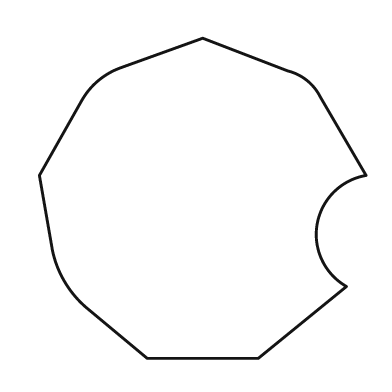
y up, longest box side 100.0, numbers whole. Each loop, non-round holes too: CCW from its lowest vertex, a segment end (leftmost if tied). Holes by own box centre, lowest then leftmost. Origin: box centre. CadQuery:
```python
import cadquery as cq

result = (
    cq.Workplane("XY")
    .moveTo(-17.0, -49.0)
    .lineTo(17.0, -49.0)
    .lineTo(44.0, -27.0)
    .threePointArc((35.0, -8.0), (50.0, 7.0))
    .lineTo(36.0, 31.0)
    .threePointArc((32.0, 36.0), (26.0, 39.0))
    .lineTo(0.0, 49.0)
    .lineTo(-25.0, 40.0)
    .threePointArc((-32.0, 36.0), (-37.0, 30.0))
    .lineTo(-50.0, 7.0)
    .lineTo(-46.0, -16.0)
    .threePointArc((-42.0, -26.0), (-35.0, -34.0))
    .close()
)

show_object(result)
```